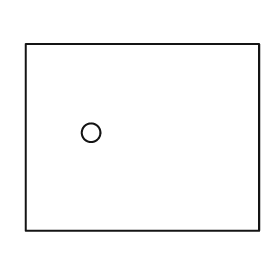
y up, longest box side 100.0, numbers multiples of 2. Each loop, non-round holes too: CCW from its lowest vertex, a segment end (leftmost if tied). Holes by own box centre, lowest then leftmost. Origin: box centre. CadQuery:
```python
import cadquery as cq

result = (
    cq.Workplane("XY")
    .moveTo(-50.0, -40.0)
    .lineTo(50.0, -40.0)
    .lineTo(50.0, 40.0)
    .lineTo(-50.0, 40.0)
    .close()
    .moveTo(-22.0, 2.0)
    .circle(4.0)
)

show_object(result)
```